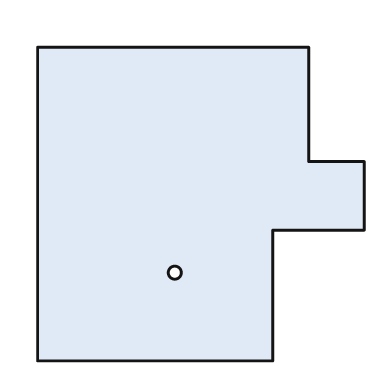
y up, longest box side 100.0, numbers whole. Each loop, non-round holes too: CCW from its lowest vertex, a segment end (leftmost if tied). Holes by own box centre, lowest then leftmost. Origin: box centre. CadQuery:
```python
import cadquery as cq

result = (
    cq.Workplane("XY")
    .moveTo(-50.0, -48.0)
    .lineTo(22.0, -48.0)
    .lineTo(22.0, -8.0)
    .lineTo(50.0, -8.0)
    .lineTo(50.0, 13.0)
    .lineTo(33.0, 13.0)
    .lineTo(33.0, 48.0)
    .lineTo(-50.0, 48.0)
    .close()
    .moveTo(-8.0, -21.0)
    .circle(2.0)
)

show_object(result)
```